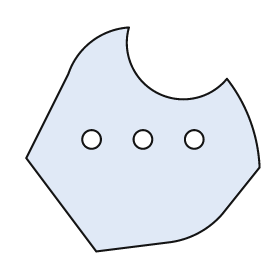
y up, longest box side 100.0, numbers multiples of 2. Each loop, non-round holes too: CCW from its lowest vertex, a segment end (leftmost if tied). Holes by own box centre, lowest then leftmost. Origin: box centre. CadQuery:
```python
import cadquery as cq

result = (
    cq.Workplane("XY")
    .moveTo(-20.0, -48.0)
    .lineTo(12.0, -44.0)
    .threePointArc((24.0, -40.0), (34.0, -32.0))
    .lineTo(50.0, -12.0)
    .threePointArc((46.0, 8.0), (36.0, 26.0))
    .threePointArc((6.0, 20.0), (-6.0, 48.0))
    .threePointArc((-22.0, 42.0), (-32.0, 28.0))
    .lineTo(-50.0, -8.0)
    .close()
    .moveTo(-22.0, 0.0)
    .circle(4.0)
    .moveTo(0.0, 0.0)
    .circle(4.0)
    .moveTo(22.0, 0.0)
    .circle(4.0)
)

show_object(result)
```